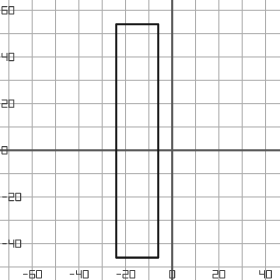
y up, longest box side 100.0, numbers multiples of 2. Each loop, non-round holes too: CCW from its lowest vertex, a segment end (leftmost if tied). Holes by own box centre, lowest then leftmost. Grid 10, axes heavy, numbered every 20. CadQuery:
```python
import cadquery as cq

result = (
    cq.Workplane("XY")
    .moveTo(-24.0, -46.0)
    .lineTo(-6.0, -46.0)
    .lineTo(-6.0, 54.0)
    .lineTo(-24.0, 54.0)
    .close()
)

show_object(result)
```